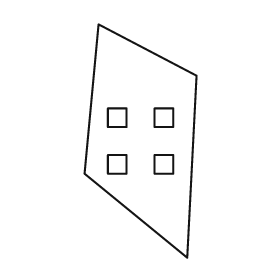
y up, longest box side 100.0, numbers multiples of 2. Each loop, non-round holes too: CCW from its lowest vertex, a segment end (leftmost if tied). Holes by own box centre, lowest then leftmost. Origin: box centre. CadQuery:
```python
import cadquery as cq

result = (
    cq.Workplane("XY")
    .moveTo(20.0, -50.0)
    .lineTo(24.0, 28.0)
    .lineTo(-18.0, 50.0)
    .lineTo(-24.0, -14.0)
    .close()
    .moveTo(-14.0, -14.0)
    .lineTo(-6.0, -14.0)
    .lineTo(-6.0, -6.0)
    .lineTo(-14.0, -6.0)
    .close()
    .moveTo(6.0, -14.0)
    .lineTo(14.0, -14.0)
    .lineTo(14.0, -6.0)
    .lineTo(6.0, -6.0)
    .close()
    .moveTo(-14.0, 6.0)
    .lineTo(-6.0, 6.0)
    .lineTo(-6.0, 14.0)
    .lineTo(-14.0, 14.0)
    .close()
    .moveTo(6.0, 6.0)
    .lineTo(14.0, 6.0)
    .lineTo(14.0, 14.0)
    .lineTo(6.0, 14.0)
    .close()
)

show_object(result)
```